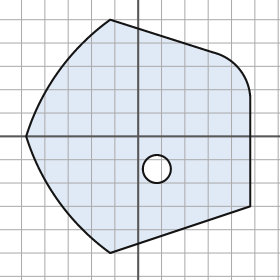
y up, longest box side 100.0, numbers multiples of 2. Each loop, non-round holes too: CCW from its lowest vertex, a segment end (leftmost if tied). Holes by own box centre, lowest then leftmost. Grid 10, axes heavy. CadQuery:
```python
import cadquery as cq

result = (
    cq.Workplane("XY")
    .moveTo(-12.0, -50.0)
    .lineTo(48.0, -30.0)
    .lineTo(48.0, 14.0)
    .threePointArc((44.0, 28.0), (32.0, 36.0))
    .lineTo(-12.0, 50.0)
    .threePointArc((-34.0, 28.0), (-48.0, 0.0))
    .threePointArc((-34.0, -28.0), (-12.0, -50.0))
    .close()
    .moveTo(8.0, -14.0)
    .circle(6.0)
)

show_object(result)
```